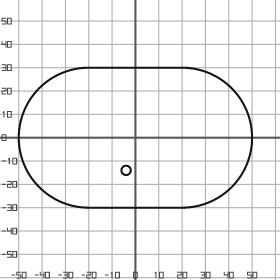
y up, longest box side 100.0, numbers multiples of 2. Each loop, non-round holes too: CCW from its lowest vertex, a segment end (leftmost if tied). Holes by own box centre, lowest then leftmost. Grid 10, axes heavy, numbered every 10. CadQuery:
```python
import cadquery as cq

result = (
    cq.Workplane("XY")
    .moveTo(-20.0, -30.0)
    .lineTo(20.0, -30.0)
    .threePointArc((50.0, 0.0), (20.0, 30.0))
    .lineTo(-20.0, 30.0)
    .threePointArc((-50.0, 0.0), (-20.0, -30.0))
    .close()
    .moveTo(-4.0, -14.0)
    .circle(2.0)
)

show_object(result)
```